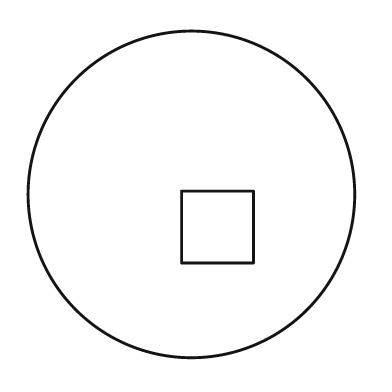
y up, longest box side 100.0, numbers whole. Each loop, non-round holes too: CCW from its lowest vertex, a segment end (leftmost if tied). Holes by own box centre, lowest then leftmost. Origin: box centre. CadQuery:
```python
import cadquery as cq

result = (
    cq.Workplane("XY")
    .moveTo(0.0, 0.0)
    .circle(50.0)
    .moveTo(-3.0, -21.0)
    .lineTo(19.0, -21.0)
    .lineTo(19.0, 1.0)
    .lineTo(-3.0, 1.0)
    .close()
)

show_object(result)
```